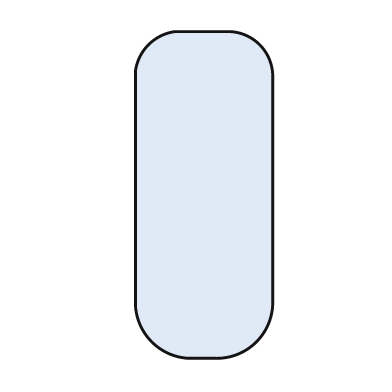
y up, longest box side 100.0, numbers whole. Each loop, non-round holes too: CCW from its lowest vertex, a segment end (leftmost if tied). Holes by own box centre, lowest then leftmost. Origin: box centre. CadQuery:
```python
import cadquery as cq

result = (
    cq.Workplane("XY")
    .moveTo(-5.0, -50.0)
    .lineTo(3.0, -50.0)
    .threePointArc((16.0, -45.0), (21.0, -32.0))
    .lineTo(21.0, 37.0)
    .threePointArc((17.0, 46.0), (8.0, 50.0))
    .lineTo(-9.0, 50.0)
    .threePointArc((-17.0, 46.0), (-21.0, 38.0))
    .lineTo(-21.0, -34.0)
    .threePointArc((-16.0, -45.0), (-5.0, -50.0))
    .close()
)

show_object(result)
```